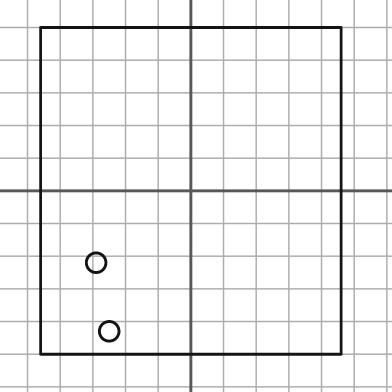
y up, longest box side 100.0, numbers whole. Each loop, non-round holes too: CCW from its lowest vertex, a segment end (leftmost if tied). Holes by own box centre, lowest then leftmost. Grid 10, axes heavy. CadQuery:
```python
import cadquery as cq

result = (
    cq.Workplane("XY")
    .moveTo(-46.0, -50.0)
    .lineTo(46.0, -50.0)
    .lineTo(46.0, 50.0)
    .lineTo(-46.0, 50.0)
    .close()
    .moveTo(-25.0, -43.0)
    .circle(3.0)
    .moveTo(-29.0, -22.0)
    .circle(3.0)
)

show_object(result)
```